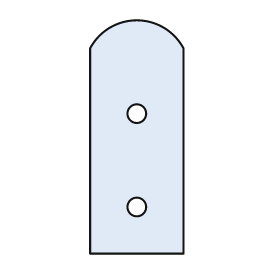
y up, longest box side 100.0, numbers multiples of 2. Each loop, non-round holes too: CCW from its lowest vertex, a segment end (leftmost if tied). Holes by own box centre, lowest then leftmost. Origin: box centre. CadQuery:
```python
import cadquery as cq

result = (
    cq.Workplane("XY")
    .moveTo(-20.0, -50.0)
    .lineTo(20.0, -50.0)
    .lineTo(20.0, 38.0)
    .threePointArc((0.0, 50.0), (-20.0, 38.0))
    .close()
    .moveTo(0.0, -30.0)
    .circle(4.0)
    .moveTo(0.0, 10.0)
    .circle(4.0)
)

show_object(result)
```